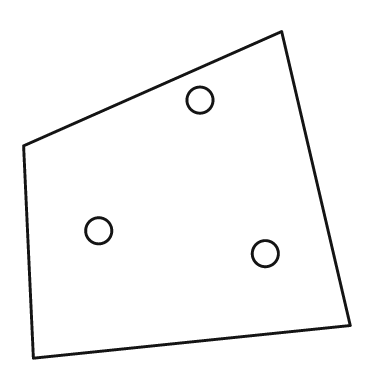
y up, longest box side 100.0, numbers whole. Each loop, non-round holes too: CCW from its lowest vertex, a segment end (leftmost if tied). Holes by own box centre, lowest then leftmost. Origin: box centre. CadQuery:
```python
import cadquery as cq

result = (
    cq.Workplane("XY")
    .moveTo(-47.0, -50.0)
    .lineTo(50.0, -40.0)
    .lineTo(29.0, 50.0)
    .lineTo(-50.0, 15.0)
    .close()
    .moveTo(24.0, -18.0)
    .circle(4.0)
    .moveTo(-27.0, -11.0)
    .circle(4.0)
    .moveTo(4.0, 29.0)
    .circle(4.0)
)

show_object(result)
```